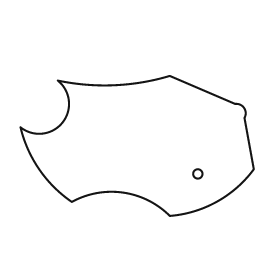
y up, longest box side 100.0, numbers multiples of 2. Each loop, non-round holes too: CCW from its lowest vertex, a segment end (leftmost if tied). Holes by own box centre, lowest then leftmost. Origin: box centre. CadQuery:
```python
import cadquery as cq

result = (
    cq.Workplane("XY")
    .moveTo(14.0, -30.0)
    .threePointArc((34.0, -24.0), (50.0, -10.0))
    .lineTo(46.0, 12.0)
    .threePointArc((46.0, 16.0), (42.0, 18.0))
    .lineTo(14.0, 30.0)
    .threePointArc((-10.0, 26.0), (-34.0, 28.0))
    .threePointArc((-32.0, 10.0), (-50.0, 8.0))
    .threePointArc((-42.0, -10.0), (-28.0, -24.0))
    .threePointArc((-6.0, -20.0), (14.0, -30.0))
    .close()
    .moveTo(26.0, -12.0)
    .circle(2.0)
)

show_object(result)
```